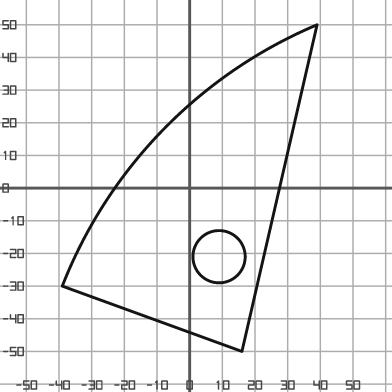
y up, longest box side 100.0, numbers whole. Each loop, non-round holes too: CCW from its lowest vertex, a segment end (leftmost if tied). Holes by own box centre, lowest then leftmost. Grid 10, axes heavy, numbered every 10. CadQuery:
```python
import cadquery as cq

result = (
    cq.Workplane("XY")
    .moveTo(16.0, -50.0)
    .lineTo(39.0, 50.0)
    .threePointArc((-8.0, 18.0), (-39.0, -30.0))
    .close()
    .moveTo(9.0, -21.0)
    .circle(8.0)
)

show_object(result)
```